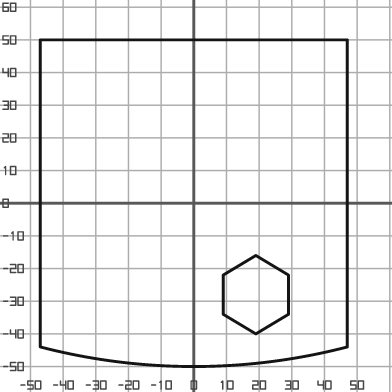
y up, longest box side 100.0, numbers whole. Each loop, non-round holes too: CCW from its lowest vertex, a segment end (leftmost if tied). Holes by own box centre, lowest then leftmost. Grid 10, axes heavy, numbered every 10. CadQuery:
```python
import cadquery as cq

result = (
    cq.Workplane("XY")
    .moveTo(-47.0, -44.0)
    .threePointArc((0.0, -50.0), (47.0, -44.0))
    .lineTo(47.0, 50.0)
    .lineTo(-47.0, 50.0)
    .close()
    .moveTo(19.0, -40.0)
    .lineTo(29.0, -34.0)
    .lineTo(29.0, -22.0)
    .lineTo(19.0, -16.0)
    .lineTo(9.0, -22.0)
    .lineTo(9.0, -34.0)
    .close()
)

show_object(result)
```